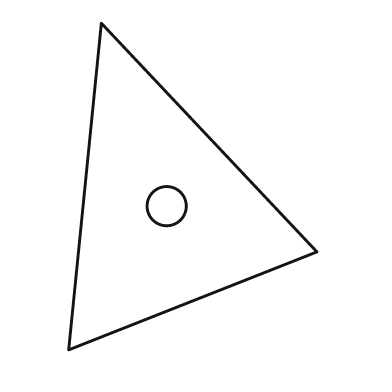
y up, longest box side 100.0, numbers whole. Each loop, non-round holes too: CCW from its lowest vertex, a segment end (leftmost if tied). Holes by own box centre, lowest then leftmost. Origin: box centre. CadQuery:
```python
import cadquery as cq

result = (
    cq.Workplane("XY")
    .moveTo(-38.0, -50.0)
    .lineTo(38.0, -20.0)
    .lineTo(-28.0, 50.0)
    .close()
    .moveTo(-8.0, -6.0)
    .circle(6.0)
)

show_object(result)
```